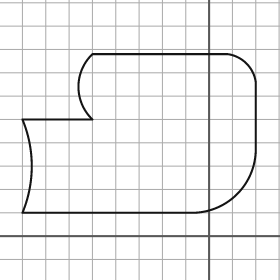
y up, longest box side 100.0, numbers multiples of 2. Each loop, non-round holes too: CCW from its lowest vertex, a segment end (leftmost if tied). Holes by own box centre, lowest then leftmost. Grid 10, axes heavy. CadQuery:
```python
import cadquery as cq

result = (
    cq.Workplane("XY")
    .moveTo(-80.0, 10.0)
    .lineTo(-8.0, 10.0)
    .threePointArc((12.0, 18.0), (20.0, 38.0))
    .lineTo(20.0, 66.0)
    .threePointArc((16.0, 74.0), (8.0, 78.0))
    .lineTo(-50.0, 78.0)
    .threePointArc((-56.0, 64.0), (-50.0, 50.0))
    .lineTo(-80.0, 50.0)
    .threePointArc((-76.0, 30.0), (-80.0, 10.0))
    .close()
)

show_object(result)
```